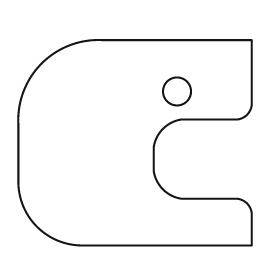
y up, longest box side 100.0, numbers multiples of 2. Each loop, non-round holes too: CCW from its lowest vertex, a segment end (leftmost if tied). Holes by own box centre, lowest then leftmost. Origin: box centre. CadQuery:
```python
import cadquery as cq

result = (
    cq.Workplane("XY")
    .moveTo(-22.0, -44.0)
    .lineTo(50.0, -44.0)
    .lineTo(50.0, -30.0)
    .threePointArc((48.0, -26.0), (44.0, -24.0))
    .lineTo(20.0, -24.0)
    .threePointArc((12.0, -20.0), (8.0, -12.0))
    .lineTo(8.0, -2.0)
    .threePointArc((12.0, 6.0), (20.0, 10.0))
    .lineTo(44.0, 10.0)
    .threePointArc((48.0, 12.0), (50.0, 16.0))
    .lineTo(50.0, 44.0)
    .lineTo(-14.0, 44.0)
    .threePointArc((-40.0, 34.0), (-50.0, 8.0))
    .lineTo(-50.0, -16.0)
    .threePointArc((-42.0, -36.0), (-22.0, -44.0))
    .close()
    .moveTo(18.0, 22.0)
    .circle(6.0)
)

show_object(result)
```